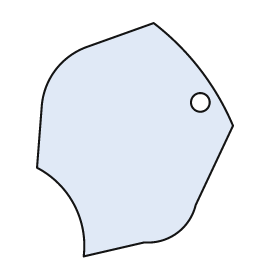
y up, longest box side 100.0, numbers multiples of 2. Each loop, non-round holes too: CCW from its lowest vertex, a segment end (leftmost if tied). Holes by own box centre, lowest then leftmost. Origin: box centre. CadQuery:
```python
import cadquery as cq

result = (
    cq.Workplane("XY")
    .moveTo(-22.0, -50.0)
    .lineTo(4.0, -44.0)
    .threePointArc((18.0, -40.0), (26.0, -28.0))
    .lineTo(42.0, 6.0)
    .threePointArc((28.0, 30.0), (8.0, 50.0))
    .lineTo(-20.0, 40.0)
    .threePointArc((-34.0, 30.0), (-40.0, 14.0))
    .lineTo(-42.0, -12.0)
    .threePointArc((-26.0, -28.0), (-22.0, -50.0))
    .close()
    .moveTo(28.0, 16.0)
    .circle(4.0)
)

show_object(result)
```